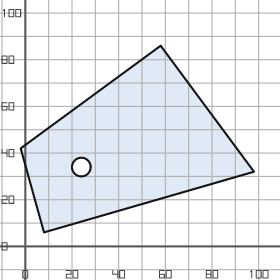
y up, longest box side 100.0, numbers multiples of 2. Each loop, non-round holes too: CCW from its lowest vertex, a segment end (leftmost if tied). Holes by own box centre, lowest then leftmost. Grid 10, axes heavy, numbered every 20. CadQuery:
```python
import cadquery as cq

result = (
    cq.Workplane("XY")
    .moveTo(8.0, 6.0)
    .lineTo(98.0, 32.0)
    .lineTo(58.0, 86.0)
    .lineTo(-2.0, 42.0)
    .close()
    .moveTo(24.0, 34.0)
    .circle(4.0)
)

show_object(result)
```